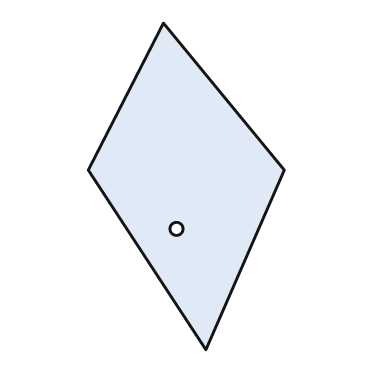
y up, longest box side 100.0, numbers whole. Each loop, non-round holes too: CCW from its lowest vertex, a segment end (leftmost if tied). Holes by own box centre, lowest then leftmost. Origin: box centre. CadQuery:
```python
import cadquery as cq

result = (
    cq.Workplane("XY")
    .moveTo(6.0, -50.0)
    .lineTo(30.0, 5.0)
    .lineTo(-7.0, 50.0)
    .lineTo(-30.0, 5.0)
    .close()
    .moveTo(-3.0, -13.0)
    .circle(2.0)
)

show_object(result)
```